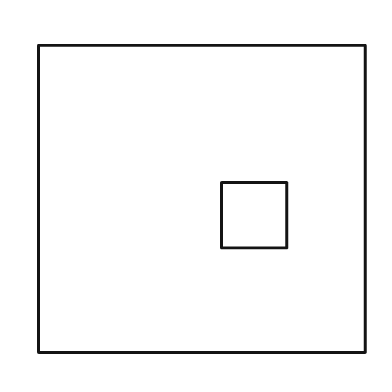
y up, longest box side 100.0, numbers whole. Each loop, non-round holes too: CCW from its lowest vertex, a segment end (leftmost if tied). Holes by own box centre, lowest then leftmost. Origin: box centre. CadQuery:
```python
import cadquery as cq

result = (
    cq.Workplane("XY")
    .moveTo(-50.0, -47.0)
    .lineTo(50.0, -47.0)
    .lineTo(50.0, 47.0)
    .lineTo(-50.0, 47.0)
    .close()
    .moveTo(6.0, -15.0)
    .lineTo(26.0, -15.0)
    .lineTo(26.0, 5.0)
    .lineTo(6.0, 5.0)
    .close()
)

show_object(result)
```